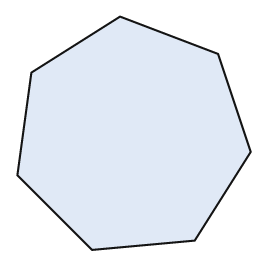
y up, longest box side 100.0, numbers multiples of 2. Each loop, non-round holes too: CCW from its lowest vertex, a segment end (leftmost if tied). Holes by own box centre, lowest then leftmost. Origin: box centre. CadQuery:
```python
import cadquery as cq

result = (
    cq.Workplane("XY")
    .moveTo(-18.0, -50.0)
    .lineTo(26.0, -46.0)
    .lineTo(50.0, -8.0)
    .lineTo(36.0, 34.0)
    .lineTo(-6.0, 50.0)
    .lineTo(-44.0, 26.0)
    .lineTo(-50.0, -18.0)
    .close()
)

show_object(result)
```